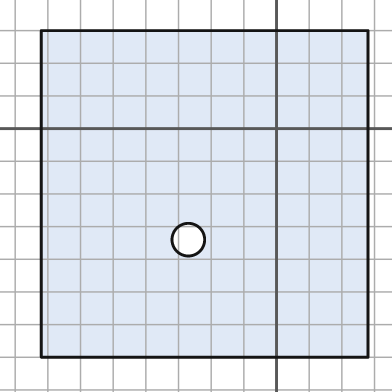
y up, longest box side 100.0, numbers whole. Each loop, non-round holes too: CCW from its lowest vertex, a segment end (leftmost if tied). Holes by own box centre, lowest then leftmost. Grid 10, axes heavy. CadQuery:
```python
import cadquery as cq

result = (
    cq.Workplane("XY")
    .moveTo(-72.0, -70.0)
    .lineTo(28.0, -70.0)
    .lineTo(28.0, 30.0)
    .lineTo(-72.0, 30.0)
    .close()
    .moveTo(-27.0, -34.0)
    .circle(5.0)
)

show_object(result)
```